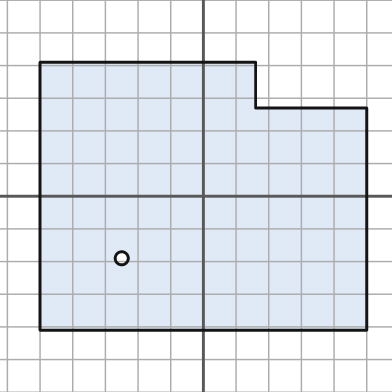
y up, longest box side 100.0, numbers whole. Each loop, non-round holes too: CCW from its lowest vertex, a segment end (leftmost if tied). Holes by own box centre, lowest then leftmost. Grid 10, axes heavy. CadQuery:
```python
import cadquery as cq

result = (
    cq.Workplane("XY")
    .moveTo(-50.0, -41.0)
    .lineTo(50.0, -41.0)
    .lineTo(50.0, 27.0)
    .lineTo(16.0, 27.0)
    .lineTo(16.0, 41.0)
    .lineTo(-50.0, 41.0)
    .close()
    .moveTo(-25.0, -19.0)
    .circle(2.0)
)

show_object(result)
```